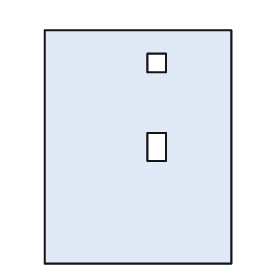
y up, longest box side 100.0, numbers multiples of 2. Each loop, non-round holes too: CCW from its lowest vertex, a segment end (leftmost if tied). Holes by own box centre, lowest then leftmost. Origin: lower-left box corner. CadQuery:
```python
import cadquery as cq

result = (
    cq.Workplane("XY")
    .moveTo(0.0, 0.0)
    .lineTo(80.0, 0.0)
    .lineTo(80.0, 100.0)
    .lineTo(0.0, 100.0)
    .close()
    .moveTo(44.0, 44.0)
    .lineTo(52.0, 44.0)
    .lineTo(52.0, 56.0)
    .lineTo(44.0, 56.0)
    .close()
    .moveTo(44.0, 82.0)
    .lineTo(52.0, 82.0)
    .lineTo(52.0, 90.0)
    .lineTo(44.0, 90.0)
    .close()
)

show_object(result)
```